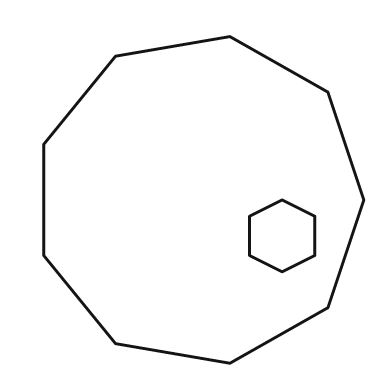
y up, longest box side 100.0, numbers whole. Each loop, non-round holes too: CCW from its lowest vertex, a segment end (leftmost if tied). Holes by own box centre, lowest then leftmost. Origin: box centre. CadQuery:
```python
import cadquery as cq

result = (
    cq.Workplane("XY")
    .moveTo(8.0, -50.0)
    .lineTo(38.0, -33.0)
    .lineTo(49.0, 0.0)
    .lineTo(38.0, 33.0)
    .lineTo(8.0, 50.0)
    .lineTo(-27.0, 44.0)
    .lineTo(-49.0, 17.0)
    .lineTo(-49.0, -17.0)
    .lineTo(-27.0, -44.0)
    .close()
    .moveTo(24.0, -22.0)
    .lineTo(34.0, -17.0)
    .lineTo(34.0, -5.0)
    .lineTo(24.0, 0.0)
    .lineTo(14.0, -5.0)
    .lineTo(14.0, -17.0)
    .close()
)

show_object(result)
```